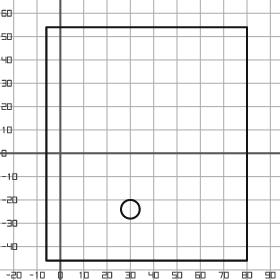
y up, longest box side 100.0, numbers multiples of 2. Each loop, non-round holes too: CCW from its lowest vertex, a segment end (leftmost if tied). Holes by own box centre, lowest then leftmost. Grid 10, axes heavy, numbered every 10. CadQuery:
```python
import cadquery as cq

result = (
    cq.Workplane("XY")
    .moveTo(-6.0, -46.0)
    .lineTo(80.0, -46.0)
    .lineTo(80.0, 54.0)
    .lineTo(-6.0, 54.0)
    .close()
    .moveTo(30.0, -24.0)
    .circle(4.0)
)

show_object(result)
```